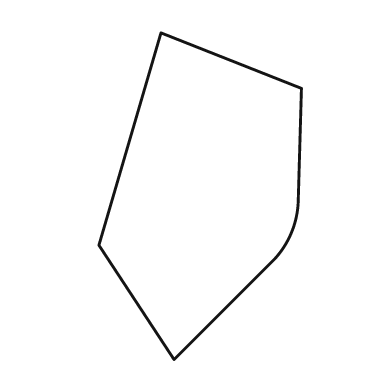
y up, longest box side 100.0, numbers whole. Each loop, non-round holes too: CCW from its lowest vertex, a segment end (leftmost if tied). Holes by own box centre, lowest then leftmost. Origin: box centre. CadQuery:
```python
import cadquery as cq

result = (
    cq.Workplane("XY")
    .moveTo(-8.0, -50.0)
    .lineTo(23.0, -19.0)
    .threePointArc((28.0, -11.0), (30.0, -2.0))
    .lineTo(31.0, 33.0)
    .lineTo(-12.0, 50.0)
    .lineTo(-31.0, -15.0)
    .close()
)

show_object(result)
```